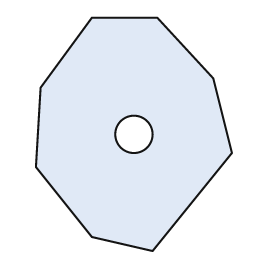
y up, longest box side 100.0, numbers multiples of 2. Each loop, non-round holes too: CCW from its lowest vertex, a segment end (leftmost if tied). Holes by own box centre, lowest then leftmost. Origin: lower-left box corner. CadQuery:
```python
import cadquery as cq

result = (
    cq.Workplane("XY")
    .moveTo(50.0, 0.0)
    .lineTo(84.0, 42.0)
    .lineTo(76.0, 74.0)
    .lineTo(52.0, 100.0)
    .lineTo(24.0, 100.0)
    .lineTo(2.0, 70.0)
    .lineTo(0.0, 36.0)
    .lineTo(24.0, 6.0)
    .close()
    .moveTo(42.0, 50.0)
    .circle(8.0)
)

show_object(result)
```